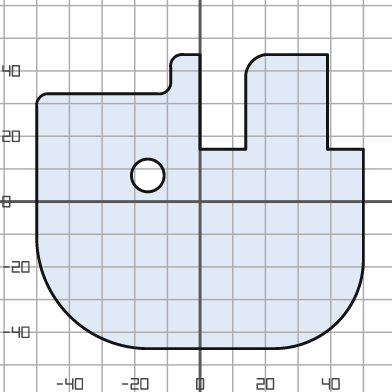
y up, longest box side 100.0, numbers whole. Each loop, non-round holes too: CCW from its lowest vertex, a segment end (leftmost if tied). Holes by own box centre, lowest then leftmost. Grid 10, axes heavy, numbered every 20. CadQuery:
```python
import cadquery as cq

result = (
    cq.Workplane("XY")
    .moveTo(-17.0, -45.0)
    .lineTo(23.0, -45.0)
    .threePointArc((42.0, -37.0), (50.0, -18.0))
    .lineTo(50.0, 16.0)
    .lineTo(39.0, 16.0)
    .lineTo(39.0, 45.0)
    .lineTo(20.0, 45.0)
    .threePointArc((16.0, 43.0), (14.0, 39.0))
    .lineTo(14.0, 16.0)
    .lineTo(0.0, 16.0)
    .lineTo(0.0, 45.0)
    .lineTo(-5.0, 45.0)
    .threePointArc((-8.0, 44.0), (-9.0, 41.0))
    .lineTo(-9.0, 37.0)
    .threePointArc((-10.0, 34.0), (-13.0, 33.0))
    .lineTo(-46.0, 33.0)
    .threePointArc((-49.0, 32.0), (-50.0, 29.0))
    .lineTo(-50.0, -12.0)
    .threePointArc((-40.0, -35.0), (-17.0, -45.0))
    .close()
    .moveTo(-16.0, 8.0)
    .circle(5.0)
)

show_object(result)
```